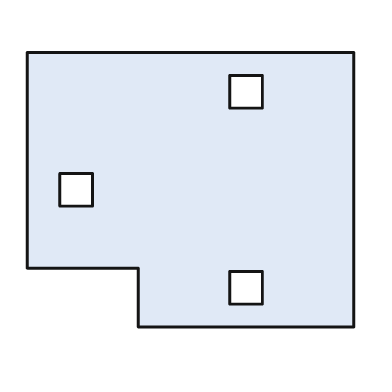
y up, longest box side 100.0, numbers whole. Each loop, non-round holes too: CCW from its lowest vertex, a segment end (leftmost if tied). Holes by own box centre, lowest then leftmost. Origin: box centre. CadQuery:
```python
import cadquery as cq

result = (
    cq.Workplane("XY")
    .moveTo(-16.0, -42.0)
    .lineTo(50.0, -42.0)
    .lineTo(50.0, 42.0)
    .lineTo(-50.0, 42.0)
    .lineTo(-50.0, -24.0)
    .lineTo(-16.0, -24.0)
    .close()
    .moveTo(12.0, -35.0)
    .lineTo(22.0, -35.0)
    .lineTo(22.0, -25.0)
    .lineTo(12.0, -25.0)
    .close()
    .moveTo(-40.0, -5.0)
    .lineTo(-30.0, -5.0)
    .lineTo(-30.0, 5.0)
    .lineTo(-40.0, 5.0)
    .close()
    .moveTo(12.0, 25.0)
    .lineTo(22.0, 25.0)
    .lineTo(22.0, 35.0)
    .lineTo(12.0, 35.0)
    .close()
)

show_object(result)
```